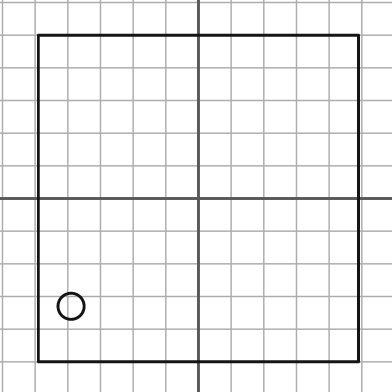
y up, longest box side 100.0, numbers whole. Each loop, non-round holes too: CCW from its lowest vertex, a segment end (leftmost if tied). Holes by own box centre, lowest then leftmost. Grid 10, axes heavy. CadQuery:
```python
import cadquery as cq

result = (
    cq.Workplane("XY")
    .moveTo(-49.0, -50.0)
    .lineTo(49.0, -50.0)
    .lineTo(49.0, 50.0)
    .lineTo(-49.0, 50.0)
    .close()
    .moveTo(-39.0, -33.0)
    .circle(4.0)
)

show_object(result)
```